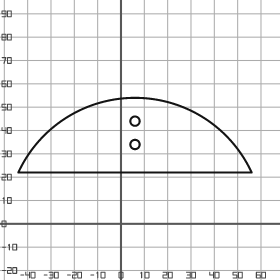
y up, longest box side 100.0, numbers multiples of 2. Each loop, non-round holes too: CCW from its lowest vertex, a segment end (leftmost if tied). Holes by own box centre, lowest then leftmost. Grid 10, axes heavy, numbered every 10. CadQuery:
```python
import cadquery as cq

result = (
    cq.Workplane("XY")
    .moveTo(-44.0, 22.0)
    .lineTo(56.0, 22.0)
    .threePointArc((6.0, 54.0), (-44.0, 22.0))
    .close()
    .moveTo(6.0, 34.0)
    .circle(2.0)
    .moveTo(6.0, 44.0)
    .circle(2.0)
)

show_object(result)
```